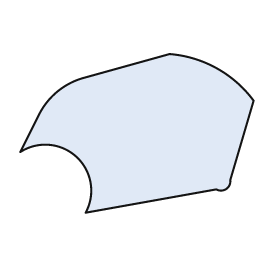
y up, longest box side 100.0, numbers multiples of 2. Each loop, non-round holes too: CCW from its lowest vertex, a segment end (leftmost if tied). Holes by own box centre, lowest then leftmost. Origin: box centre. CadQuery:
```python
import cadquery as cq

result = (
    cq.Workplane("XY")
    .moveTo(-22.0, -34.0)
    .lineTo(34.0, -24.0)
    .threePointArc((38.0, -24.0), (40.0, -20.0))
    .lineTo(50.0, 14.0)
    .threePointArc((34.0, 28.0), (14.0, 34.0))
    .lineTo(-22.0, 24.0)
    .threePointArc((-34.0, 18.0), (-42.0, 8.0))
    .lineTo(-50.0, -8.0)
    .threePointArc((-26.0, -10.0), (-22.0, -34.0))
    .close()
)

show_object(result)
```